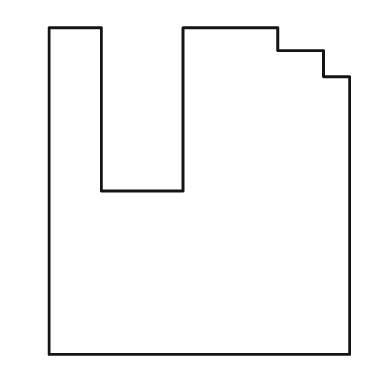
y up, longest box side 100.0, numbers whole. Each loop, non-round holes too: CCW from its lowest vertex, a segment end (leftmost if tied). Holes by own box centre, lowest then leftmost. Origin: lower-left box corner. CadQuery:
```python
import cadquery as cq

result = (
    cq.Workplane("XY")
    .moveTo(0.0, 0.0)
    .lineTo(92.0, 0.0)
    .lineTo(92.0, 85.0)
    .lineTo(84.0, 85.0)
    .lineTo(84.0, 93.0)
    .lineTo(70.0, 93.0)
    .lineTo(70.0, 100.0)
    .lineTo(41.0, 100.0)
    .lineTo(41.0, 50.0)
    .lineTo(16.0, 50.0)
    .lineTo(16.0, 100.0)
    .lineTo(0.0, 100.0)
    .close()
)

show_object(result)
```